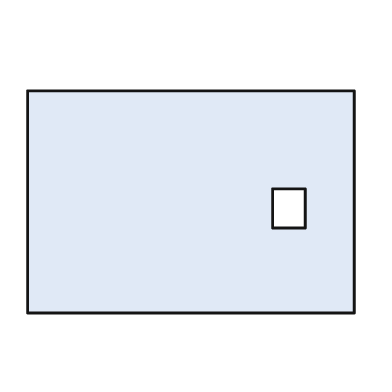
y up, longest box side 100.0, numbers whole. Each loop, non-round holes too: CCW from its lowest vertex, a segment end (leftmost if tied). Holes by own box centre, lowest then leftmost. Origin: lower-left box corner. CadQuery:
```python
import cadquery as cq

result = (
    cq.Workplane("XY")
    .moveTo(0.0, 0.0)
    .lineTo(100.0, 0.0)
    .lineTo(100.0, 68.0)
    .lineTo(0.0, 68.0)
    .close()
    .moveTo(75.0, 26.0)
    .lineTo(85.0, 26.0)
    .lineTo(85.0, 38.0)
    .lineTo(75.0, 38.0)
    .close()
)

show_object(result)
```